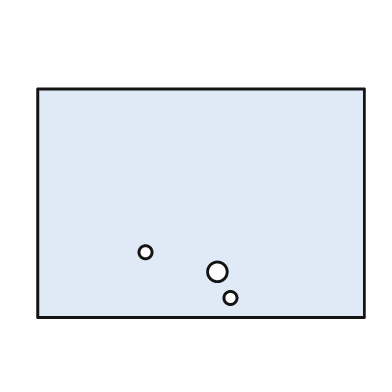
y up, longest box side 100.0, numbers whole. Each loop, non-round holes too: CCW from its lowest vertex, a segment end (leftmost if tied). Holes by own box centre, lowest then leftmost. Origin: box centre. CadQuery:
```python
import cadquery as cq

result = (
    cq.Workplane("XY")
    .moveTo(-50.0, -35.0)
    .lineTo(50.0, -35.0)
    .lineTo(50.0, 35.0)
    .lineTo(-50.0, 35.0)
    .close()
    .moveTo(9.0, -29.0)
    .circle(2.0)
    .moveTo(5.0, -21.0)
    .circle(3.0)
    .moveTo(-17.0, -15.0)
    .circle(2.0)
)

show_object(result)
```